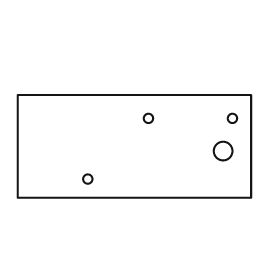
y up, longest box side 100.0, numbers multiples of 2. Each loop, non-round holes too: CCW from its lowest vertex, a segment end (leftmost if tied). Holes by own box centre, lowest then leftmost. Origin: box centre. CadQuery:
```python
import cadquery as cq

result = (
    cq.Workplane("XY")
    .moveTo(-50.0, -22.0)
    .lineTo(50.0, -22.0)
    .lineTo(50.0, 22.0)
    .lineTo(-50.0, 22.0)
    .close()
    .moveTo(-20.0, -14.0)
    .circle(2.0)
    .moveTo(38.0, -2.0)
    .circle(4.0)
    .moveTo(6.0, 12.0)
    .circle(2.0)
    .moveTo(42.0, 12.0)
    .circle(2.0)
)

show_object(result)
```